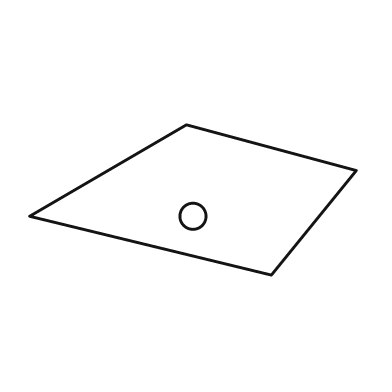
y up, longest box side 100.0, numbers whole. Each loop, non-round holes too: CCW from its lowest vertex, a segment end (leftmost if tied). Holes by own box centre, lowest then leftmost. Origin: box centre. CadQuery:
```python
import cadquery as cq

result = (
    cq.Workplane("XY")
    .moveTo(24.0, -23.0)
    .lineTo(50.0, 9.0)
    .lineTo(-2.0, 23.0)
    .lineTo(-50.0, -5.0)
    .close()
    .moveTo(0.0, -5.0)
    .circle(4.0)
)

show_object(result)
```